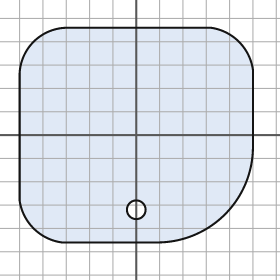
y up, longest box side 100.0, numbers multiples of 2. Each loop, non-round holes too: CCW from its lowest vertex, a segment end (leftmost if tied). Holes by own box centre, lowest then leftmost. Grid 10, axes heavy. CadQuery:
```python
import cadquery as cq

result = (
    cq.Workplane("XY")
    .moveTo(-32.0, -46.0)
    .lineTo(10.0, -46.0)
    .threePointArc((38.0, -34.0), (50.0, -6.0))
    .lineTo(50.0, 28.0)
    .threePointArc((44.0, 40.0), (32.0, 46.0))
    .lineTo(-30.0, 46.0)
    .threePointArc((-44.0, 40.0), (-50.0, 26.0))
    .lineTo(-50.0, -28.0)
    .threePointArc((-44.0, -40.0), (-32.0, -46.0))
    .close()
    .moveTo(0.0, -32.0)
    .circle(4.0)
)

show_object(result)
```